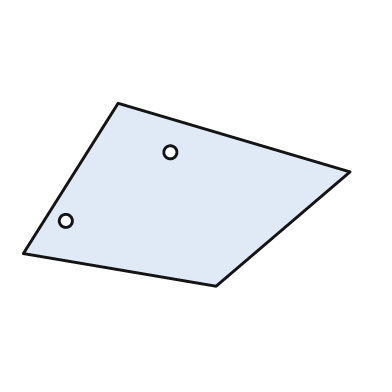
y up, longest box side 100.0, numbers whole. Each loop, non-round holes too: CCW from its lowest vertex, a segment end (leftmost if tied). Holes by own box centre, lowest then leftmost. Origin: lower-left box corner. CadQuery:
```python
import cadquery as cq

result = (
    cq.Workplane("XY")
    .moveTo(59.0, 0.0)
    .lineTo(100.0, 35.0)
    .lineTo(29.0, 56.0)
    .lineTo(0.0, 10.0)
    .close()
    .moveTo(13.0, 20.0)
    .circle(2.0)
    .moveTo(45.0, 41.0)
    .circle(2.0)
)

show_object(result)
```